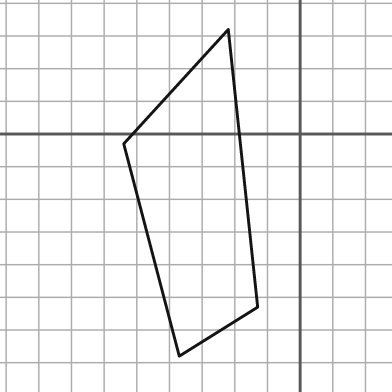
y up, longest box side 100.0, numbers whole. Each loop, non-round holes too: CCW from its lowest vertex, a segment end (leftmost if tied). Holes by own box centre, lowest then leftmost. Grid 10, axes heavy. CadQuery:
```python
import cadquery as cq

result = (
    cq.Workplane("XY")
    .moveTo(-37.0, -68.0)
    .lineTo(-13.0, -53.0)
    .lineTo(-22.0, 32.0)
    .lineTo(-54.0, -3.0)
    .close()
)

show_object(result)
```